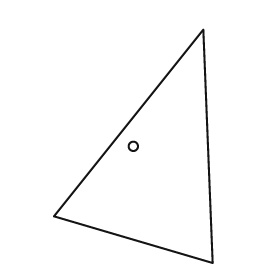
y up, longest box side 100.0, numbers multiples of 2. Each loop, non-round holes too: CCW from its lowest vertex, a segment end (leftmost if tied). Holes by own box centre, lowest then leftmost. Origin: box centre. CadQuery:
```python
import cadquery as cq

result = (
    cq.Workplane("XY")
    .moveTo(34.0, -50.0)
    .lineTo(30.0, 50.0)
    .lineTo(-34.0, -30.0)
    .close()
    .moveTo(0.0, 0.0)
    .circle(2.0)
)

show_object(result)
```